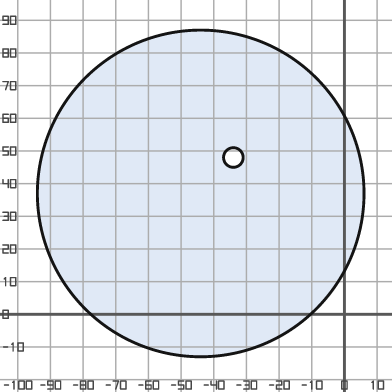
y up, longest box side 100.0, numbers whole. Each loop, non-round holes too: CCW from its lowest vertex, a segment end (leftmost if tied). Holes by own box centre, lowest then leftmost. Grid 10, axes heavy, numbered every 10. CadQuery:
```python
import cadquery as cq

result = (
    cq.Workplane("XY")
    .moveTo(-44.0, 37.0)
    .circle(50.0)
    .moveTo(-34.0, 48.0)
    .circle(3.0)
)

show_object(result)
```